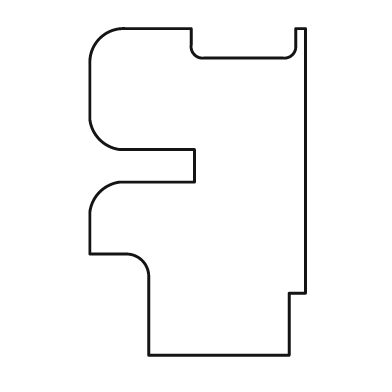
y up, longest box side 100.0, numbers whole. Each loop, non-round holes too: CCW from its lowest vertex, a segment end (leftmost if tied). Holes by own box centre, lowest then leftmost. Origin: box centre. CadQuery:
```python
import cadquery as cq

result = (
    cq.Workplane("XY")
    .moveTo(-15.0, -50.0)
    .lineTo(28.0, -50.0)
    .lineTo(28.0, -31.0)
    .lineTo(33.0, -31.0)
    .lineTo(33.0, 50.0)
    .lineTo(30.0, 50.0)
    .lineTo(30.0, 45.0)
    .threePointArc((29.0, 42.0), (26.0, 41.0))
    .lineTo(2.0, 41.0)
    .threePointArc((-1.0, 42.0), (-2.0, 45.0))
    .lineTo(-2.0, 50.0)
    .lineTo(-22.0, 50.0)
    .threePointArc((-30.0, 47.0), (-33.0, 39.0))
    .lineTo(-33.0, 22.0)
    .threePointArc((-30.0, 16.0), (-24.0, 13.0))
    .lineTo(-1.0, 13.0)
    .lineTo(-1.0, 3.0)
    .lineTo(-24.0, 3.0)
    .threePointArc((-30.0, 0.0), (-33.0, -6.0))
    .lineTo(-33.0, -19.0)
    .lineTo(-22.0, -19.0)
    .threePointArc((-17.0, -21.0), (-15.0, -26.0))
    .close()
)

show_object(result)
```